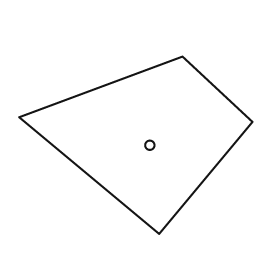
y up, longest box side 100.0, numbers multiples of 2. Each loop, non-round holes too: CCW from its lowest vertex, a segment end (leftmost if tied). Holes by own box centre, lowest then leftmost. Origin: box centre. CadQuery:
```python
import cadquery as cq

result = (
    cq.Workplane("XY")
    .moveTo(10.0, -38.0)
    .lineTo(50.0, 10.0)
    .lineTo(20.0, 38.0)
    .lineTo(-50.0, 12.0)
    .close()
    .moveTo(6.0, 0.0)
    .circle(2.0)
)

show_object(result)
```